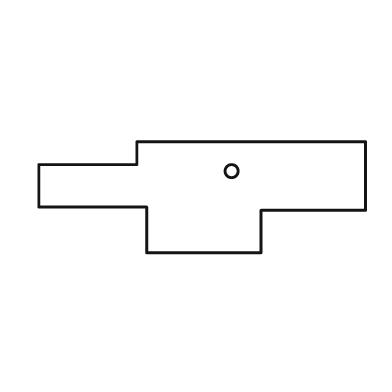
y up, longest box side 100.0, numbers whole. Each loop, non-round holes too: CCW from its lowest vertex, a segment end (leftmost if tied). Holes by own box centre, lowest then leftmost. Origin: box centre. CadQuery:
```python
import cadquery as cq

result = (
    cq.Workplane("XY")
    .moveTo(-17.0, -17.0)
    .lineTo(18.0, -17.0)
    .lineTo(18.0, -4.0)
    .lineTo(50.0, -4.0)
    .lineTo(50.0, 17.0)
    .lineTo(-20.0, 17.0)
    .lineTo(-20.0, 10.0)
    .lineTo(-50.0, 10.0)
    .lineTo(-50.0, -3.0)
    .lineTo(-17.0, -3.0)
    .close()
    .moveTo(9.0, 8.0)
    .circle(2.0)
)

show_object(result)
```